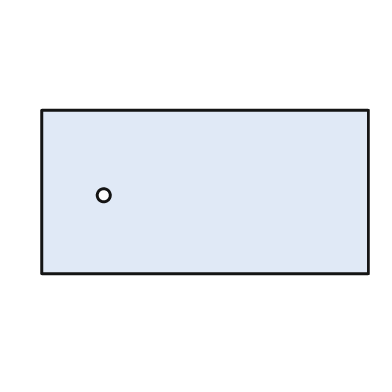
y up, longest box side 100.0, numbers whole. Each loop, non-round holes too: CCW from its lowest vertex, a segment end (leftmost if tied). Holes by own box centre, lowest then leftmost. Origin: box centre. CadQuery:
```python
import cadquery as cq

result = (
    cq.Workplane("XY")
    .moveTo(-50.0, -25.0)
    .lineTo(50.0, -25.0)
    .lineTo(50.0, 25.0)
    .lineTo(-50.0, 25.0)
    .close()
    .moveTo(-31.0, -1.0)
    .circle(2.0)
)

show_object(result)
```